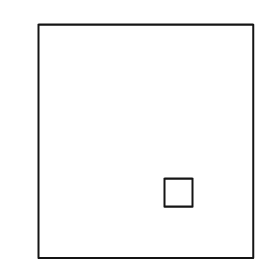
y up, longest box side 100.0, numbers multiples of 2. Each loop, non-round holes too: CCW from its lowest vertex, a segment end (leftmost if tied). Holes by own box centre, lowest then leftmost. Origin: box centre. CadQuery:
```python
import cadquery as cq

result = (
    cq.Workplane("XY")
    .moveTo(-46.0, -50.0)
    .lineTo(46.0, -50.0)
    .lineTo(46.0, 50.0)
    .lineTo(-46.0, 50.0)
    .close()
    .moveTo(8.0, -28.0)
    .lineTo(20.0, -28.0)
    .lineTo(20.0, -16.0)
    .lineTo(8.0, -16.0)
    .close()
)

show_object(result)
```